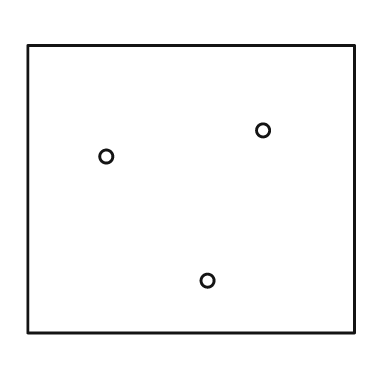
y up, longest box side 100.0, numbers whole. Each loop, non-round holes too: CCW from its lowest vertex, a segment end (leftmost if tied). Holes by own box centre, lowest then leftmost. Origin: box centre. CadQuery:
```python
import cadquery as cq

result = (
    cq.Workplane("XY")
    .moveTo(-50.0, -44.0)
    .lineTo(50.0, -44.0)
    .lineTo(50.0, 44.0)
    .lineTo(-50.0, 44.0)
    .close()
    .moveTo(5.0, -28.0)
    .circle(2.0)
    .moveTo(-26.0, 10.0)
    .circle(2.0)
    .moveTo(22.0, 18.0)
    .circle(2.0)
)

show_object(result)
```